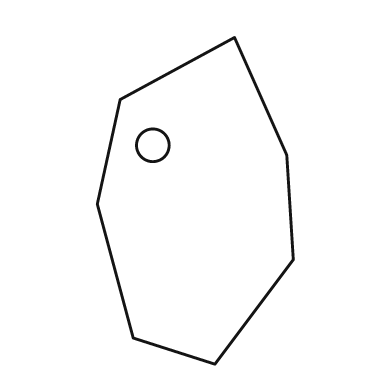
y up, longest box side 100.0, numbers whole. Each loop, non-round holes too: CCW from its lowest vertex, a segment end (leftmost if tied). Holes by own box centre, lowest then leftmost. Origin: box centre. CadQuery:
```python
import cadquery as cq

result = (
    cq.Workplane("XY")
    .moveTo(6.0, -50.0)
    .lineTo(30.0, -18.0)
    .lineTo(28.0, 14.0)
    .lineTo(12.0, 50.0)
    .lineTo(-23.0, 31.0)
    .lineTo(-30.0, -1.0)
    .lineTo(-19.0, -42.0)
    .close()
    .moveTo(-13.0, 17.0)
    .circle(5.0)
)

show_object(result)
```